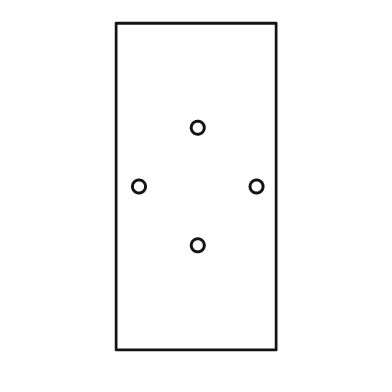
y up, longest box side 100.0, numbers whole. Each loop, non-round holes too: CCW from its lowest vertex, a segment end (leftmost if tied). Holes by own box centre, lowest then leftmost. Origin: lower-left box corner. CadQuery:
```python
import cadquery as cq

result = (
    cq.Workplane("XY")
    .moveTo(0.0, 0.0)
    .lineTo(49.0, 0.0)
    .lineTo(49.0, 100.0)
    .lineTo(0.0, 100.0)
    .close()
    .moveTo(25.0, 32.0)
    .circle(2.0)
    .moveTo(7.0, 50.0)
    .circle(2.0)
    .moveTo(43.0, 50.0)
    .circle(2.0)
    .moveTo(25.0, 68.0)
    .circle(2.0)
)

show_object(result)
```